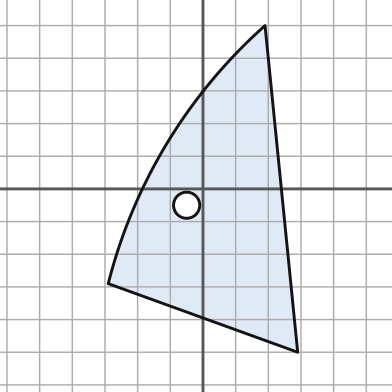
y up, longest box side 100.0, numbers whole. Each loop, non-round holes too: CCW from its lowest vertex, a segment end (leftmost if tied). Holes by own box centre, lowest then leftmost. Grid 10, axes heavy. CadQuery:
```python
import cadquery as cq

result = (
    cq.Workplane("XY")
    .moveTo(29.0, -50.0)
    .lineTo(19.0, 50.0)
    .threePointArc((-11.0, 14.0), (-29.0, -29.0))
    .close()
    .moveTo(-5.0, -5.0)
    .circle(4.0)
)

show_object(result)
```